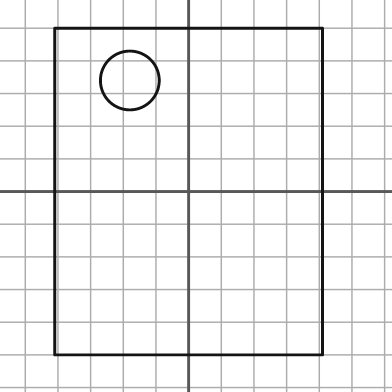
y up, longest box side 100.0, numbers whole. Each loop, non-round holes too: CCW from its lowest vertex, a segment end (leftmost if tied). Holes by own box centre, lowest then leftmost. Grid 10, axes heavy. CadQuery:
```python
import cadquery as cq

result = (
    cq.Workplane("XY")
    .moveTo(-41.0, -50.0)
    .lineTo(41.0, -50.0)
    .lineTo(41.0, 50.0)
    .lineTo(-41.0, 50.0)
    .close()
    .moveTo(-18.0, 34.0)
    .circle(9.0)
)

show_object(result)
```